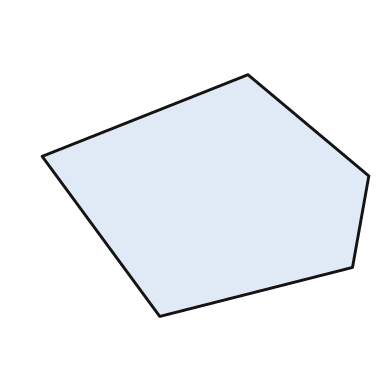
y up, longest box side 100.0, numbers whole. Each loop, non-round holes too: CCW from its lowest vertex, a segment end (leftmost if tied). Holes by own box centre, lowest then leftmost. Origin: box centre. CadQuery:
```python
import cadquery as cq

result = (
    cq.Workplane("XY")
    .moveTo(-14.0, -37.0)
    .lineTo(45.0, -22.0)
    .lineTo(50.0, 6.0)
    .lineTo(13.0, 37.0)
    .lineTo(-50.0, 12.0)
    .close()
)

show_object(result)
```